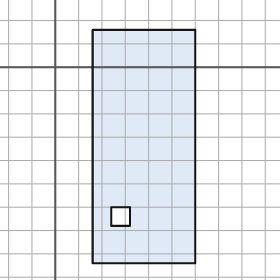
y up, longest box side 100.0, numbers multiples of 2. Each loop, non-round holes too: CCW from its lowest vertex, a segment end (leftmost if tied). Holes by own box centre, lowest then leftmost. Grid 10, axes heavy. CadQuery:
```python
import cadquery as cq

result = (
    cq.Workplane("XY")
    .moveTo(16.0, -84.0)
    .lineTo(60.0, -84.0)
    .lineTo(60.0, 16.0)
    .lineTo(16.0, 16.0)
    .close()
    .moveTo(24.0, -68.0)
    .lineTo(32.0, -68.0)
    .lineTo(32.0, -60.0)
    .lineTo(24.0, -60.0)
    .close()
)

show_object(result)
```